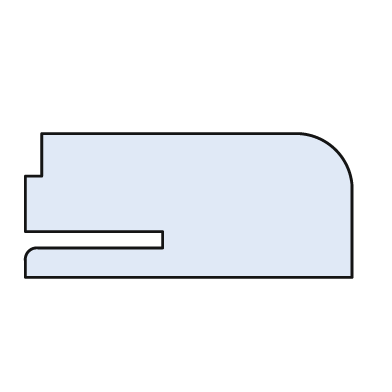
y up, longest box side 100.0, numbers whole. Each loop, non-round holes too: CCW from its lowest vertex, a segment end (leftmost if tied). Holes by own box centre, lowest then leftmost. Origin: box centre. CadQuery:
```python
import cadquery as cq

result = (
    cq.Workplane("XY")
    .moveTo(-50.0, -22.0)
    .lineTo(50.0, -22.0)
    .lineTo(50.0, 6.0)
    .threePointArc((45.0, 17.0), (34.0, 22.0))
    .lineTo(-45.0, 22.0)
    .lineTo(-45.0, 9.0)
    .lineTo(-50.0, 9.0)
    .lineTo(-50.0, -8.0)
    .lineTo(-8.0, -8.0)
    .lineTo(-8.0, -13.0)
    .lineTo(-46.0, -13.0)
    .threePointArc((-49.0, -14.0), (-50.0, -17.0))
    .close()
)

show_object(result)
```